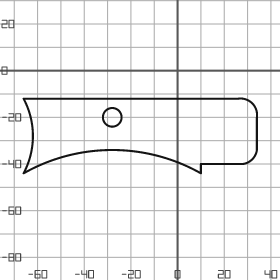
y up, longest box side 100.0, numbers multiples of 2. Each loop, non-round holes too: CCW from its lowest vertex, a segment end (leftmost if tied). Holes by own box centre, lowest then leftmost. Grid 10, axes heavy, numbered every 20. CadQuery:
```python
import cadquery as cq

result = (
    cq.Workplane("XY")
    .moveTo(-66.0, -44.0)
    .threePointArc((-28.0, -34.0), (10.0, -44.0))
    .lineTo(10.0, -40.0)
    .lineTo(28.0, -40.0)
    .threePointArc((32.0, -38.0), (34.0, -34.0))
    .lineTo(34.0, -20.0)
    .threePointArc((32.0, -14.0), (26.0, -12.0))
    .lineTo(-66.0, -12.0)
    .threePointArc((-62.0, -28.0), (-66.0, -44.0))
    .close()
    .moveTo(-28.0, -20.0)
    .circle(4.0)
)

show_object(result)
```